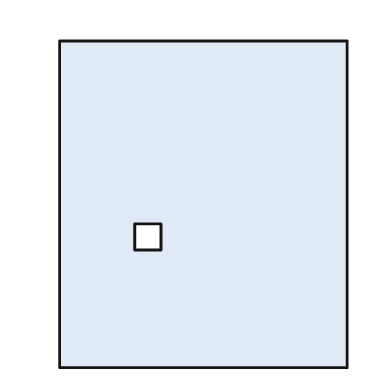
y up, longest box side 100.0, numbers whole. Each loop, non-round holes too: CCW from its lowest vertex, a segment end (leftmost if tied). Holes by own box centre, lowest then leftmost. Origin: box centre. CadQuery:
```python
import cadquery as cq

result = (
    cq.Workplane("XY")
    .moveTo(-44.0, -50.0)
    .lineTo(44.0, -50.0)
    .lineTo(44.0, 50.0)
    .lineTo(-44.0, 50.0)
    .close()
    .moveTo(-21.0, -14.0)
    .lineTo(-13.0, -14.0)
    .lineTo(-13.0, -6.0)
    .lineTo(-21.0, -6.0)
    .close()
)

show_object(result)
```